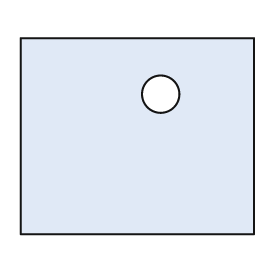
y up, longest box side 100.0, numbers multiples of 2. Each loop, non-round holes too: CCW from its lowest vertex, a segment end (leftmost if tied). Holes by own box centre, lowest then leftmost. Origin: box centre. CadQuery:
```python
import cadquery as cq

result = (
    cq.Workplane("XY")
    .moveTo(-50.0, -42.0)
    .lineTo(50.0, -42.0)
    .lineTo(50.0, 42.0)
    .lineTo(-50.0, 42.0)
    .close()
    .moveTo(10.0, 18.0)
    .circle(8.0)
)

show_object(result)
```